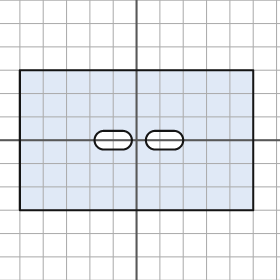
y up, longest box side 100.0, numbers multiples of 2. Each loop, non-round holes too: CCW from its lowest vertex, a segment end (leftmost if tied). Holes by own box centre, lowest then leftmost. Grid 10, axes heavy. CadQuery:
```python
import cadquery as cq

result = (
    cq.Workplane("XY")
    .moveTo(-50.0, -30.0)
    .lineTo(50.0, -30.0)
    .lineTo(50.0, 30.0)
    .lineTo(-50.0, 30.0)
    .close()
    .moveTo(-14.0, -4.0)
    .lineTo(-6.0, -4.0)
    .threePointArc((-2.0, 0.0), (-6.0, 4.0))
    .lineTo(-14.0, 4.0)
    .threePointArc((-18.0, 0.0), (-14.0, -4.0))
    .close()
    .moveTo(8.0, -4.0)
    .lineTo(16.0, -4.0)
    .threePointArc((20.0, 0.0), (16.0, 4.0))
    .lineTo(8.0, 4.0)
    .threePointArc((4.0, 0.0), (8.0, -4.0))
    .close()
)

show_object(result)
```